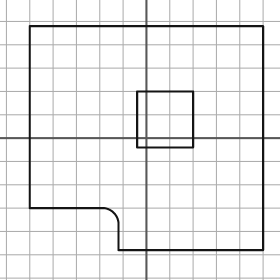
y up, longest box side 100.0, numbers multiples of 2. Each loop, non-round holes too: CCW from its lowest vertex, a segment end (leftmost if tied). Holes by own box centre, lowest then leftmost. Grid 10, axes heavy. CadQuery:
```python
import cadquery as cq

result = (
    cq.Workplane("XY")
    .moveTo(-12.0, -48.0)
    .lineTo(50.0, -48.0)
    .lineTo(50.0, 48.0)
    .lineTo(-50.0, 48.0)
    .lineTo(-50.0, -30.0)
    .lineTo(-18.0, -30.0)
    .threePointArc((-14.0, -32.0), (-12.0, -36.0))
    .close()
    .moveTo(-4.0, -4.0)
    .lineTo(20.0, -4.0)
    .lineTo(20.0, 20.0)
    .lineTo(-4.0, 20.0)
    .close()
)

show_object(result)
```